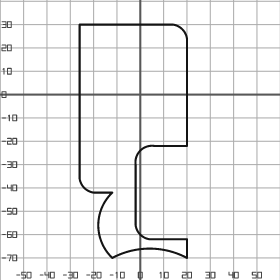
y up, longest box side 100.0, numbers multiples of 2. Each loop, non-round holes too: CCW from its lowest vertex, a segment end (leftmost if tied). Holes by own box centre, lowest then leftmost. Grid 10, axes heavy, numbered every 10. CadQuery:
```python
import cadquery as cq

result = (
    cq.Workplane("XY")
    .moveTo(-12.0, -70.0)
    .threePointArc((4.0, -66.0), (20.0, -70.0))
    .lineTo(20.0, -62.0)
    .lineTo(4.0, -62.0)
    .threePointArc((0.0, -60.0), (-2.0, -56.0))
    .lineTo(-2.0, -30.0)
    .threePointArc((0.0, -24.0), (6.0, -22.0))
    .lineTo(20.0, -22.0)
    .lineTo(20.0, 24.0)
    .threePointArc((18.0, 28.0), (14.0, 30.0))
    .lineTo(-26.0, 30.0)
    .lineTo(-26.0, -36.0)
    .threePointArc((-24.0, -40.0), (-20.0, -42.0))
    .lineTo(-12.0, -42.0)
    .threePointArc((-18.0, -56.0), (-12.0, -70.0))
    .close()
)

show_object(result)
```